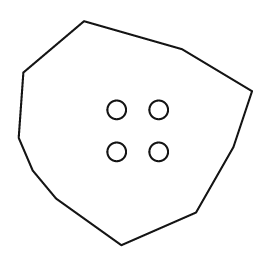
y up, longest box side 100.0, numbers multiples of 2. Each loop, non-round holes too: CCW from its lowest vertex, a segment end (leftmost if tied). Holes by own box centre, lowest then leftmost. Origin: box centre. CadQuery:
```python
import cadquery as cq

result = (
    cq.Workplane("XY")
    .moveTo(-6.0, -48.0)
    .lineTo(26.0, -34.0)
    .lineTo(42.0, -6.0)
    .lineTo(50.0, 18.0)
    .lineTo(20.0, 36.0)
    .lineTo(-22.0, 48.0)
    .lineTo(-48.0, 26.0)
    .lineTo(-50.0, -2.0)
    .lineTo(-44.0, -16.0)
    .lineTo(-34.0, -28.0)
    .close()
    .moveTo(-8.0, -8.0)
    .circle(4.0)
    .moveTo(10.0, -8.0)
    .circle(4.0)
    .moveTo(-8.0, 10.0)
    .circle(4.0)
    .moveTo(10.0, 10.0)
    .circle(4.0)
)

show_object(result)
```